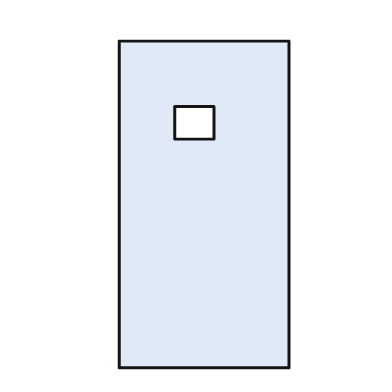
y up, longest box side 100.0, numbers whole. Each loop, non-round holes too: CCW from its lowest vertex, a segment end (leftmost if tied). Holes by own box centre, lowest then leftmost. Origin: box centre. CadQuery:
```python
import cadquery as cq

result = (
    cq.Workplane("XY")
    .moveTo(-26.0, -50.0)
    .lineTo(26.0, -50.0)
    .lineTo(26.0, 50.0)
    .lineTo(-26.0, 50.0)
    .close()
    .moveTo(-9.0, 20.0)
    .lineTo(3.0, 20.0)
    .lineTo(3.0, 30.0)
    .lineTo(-9.0, 30.0)
    .close()
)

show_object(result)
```